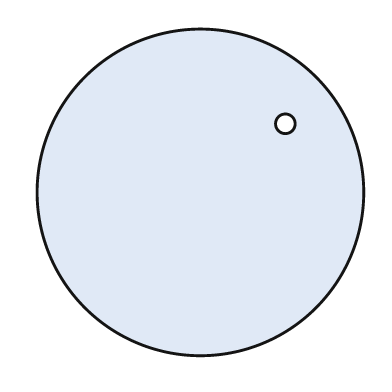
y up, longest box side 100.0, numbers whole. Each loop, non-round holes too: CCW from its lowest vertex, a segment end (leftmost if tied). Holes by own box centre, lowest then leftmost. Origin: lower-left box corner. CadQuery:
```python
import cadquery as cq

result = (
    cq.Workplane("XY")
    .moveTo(50.0, 50.0)
    .circle(50.0)
    .moveTo(76.0, 71.0)
    .circle(3.0)
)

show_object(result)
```